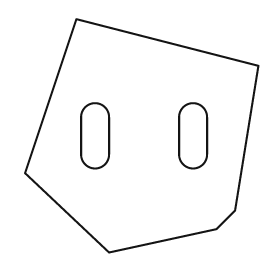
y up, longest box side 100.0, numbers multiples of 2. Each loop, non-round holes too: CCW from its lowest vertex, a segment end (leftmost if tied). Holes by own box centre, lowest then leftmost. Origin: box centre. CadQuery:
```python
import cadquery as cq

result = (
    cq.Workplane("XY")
    .moveTo(-14.0, -50.0)
    .lineTo(32.0, -40.0)
    .lineTo(40.0, -32.0)
    .lineTo(50.0, 30.0)
    .lineTo(-28.0, 50.0)
    .lineTo(-50.0, -16.0)
    .close()
    .moveTo(-26.0, -8.0)
    .threePointArc((-20.0, -14.0), (-14.0, -8.0))
    .lineTo(-14.0, 8.0)
    .threePointArc((-20.0, 14.0), (-26.0, 8.0))
    .close()
    .moveTo(16.0, -8.0)
    .threePointArc((22.0, -14.0), (28.0, -8.0))
    .lineTo(28.0, 8.0)
    .threePointArc((22.0, 14.0), (16.0, 8.0))
    .close()
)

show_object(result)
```